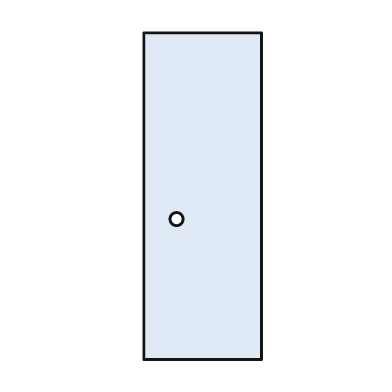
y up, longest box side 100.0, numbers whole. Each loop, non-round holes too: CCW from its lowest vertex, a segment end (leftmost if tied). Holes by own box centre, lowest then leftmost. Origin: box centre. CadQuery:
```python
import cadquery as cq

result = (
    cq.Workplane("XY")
    .moveTo(-18.0, -50.0)
    .lineTo(18.0, -50.0)
    .lineTo(18.0, 50.0)
    .lineTo(-18.0, 50.0)
    .close()
    .moveTo(-8.0, -7.0)
    .circle(2.0)
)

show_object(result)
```